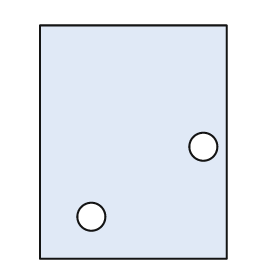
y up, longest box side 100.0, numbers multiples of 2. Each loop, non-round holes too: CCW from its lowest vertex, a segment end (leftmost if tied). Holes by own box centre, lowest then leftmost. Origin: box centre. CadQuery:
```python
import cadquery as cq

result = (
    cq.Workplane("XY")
    .moveTo(-40.0, -50.0)
    .lineTo(40.0, -50.0)
    .lineTo(40.0, 50.0)
    .lineTo(-40.0, 50.0)
    .close()
    .moveTo(-18.0, -32.0)
    .circle(6.0)
    .moveTo(30.0, -2.0)
    .circle(6.0)
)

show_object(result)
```